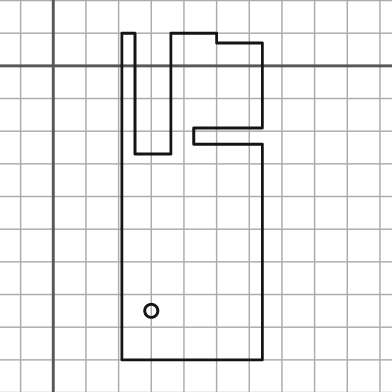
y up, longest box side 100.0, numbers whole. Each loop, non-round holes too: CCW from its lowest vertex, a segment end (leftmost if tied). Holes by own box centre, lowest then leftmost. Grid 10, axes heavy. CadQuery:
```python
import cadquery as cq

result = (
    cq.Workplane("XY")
    .moveTo(21.0, -90.0)
    .lineTo(64.0, -90.0)
    .lineTo(64.0, -24.0)
    .lineTo(43.0, -24.0)
    .lineTo(43.0, -19.0)
    .lineTo(64.0, -19.0)
    .lineTo(64.0, 7.0)
    .lineTo(50.0, 7.0)
    .lineTo(50.0, 10.0)
    .lineTo(36.0, 10.0)
    .lineTo(36.0, -27.0)
    .lineTo(25.0, -27.0)
    .lineTo(25.0, 10.0)
    .lineTo(21.0, 10.0)
    .close()
    .moveTo(30.0, -75.0)
    .circle(2.0)
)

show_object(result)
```